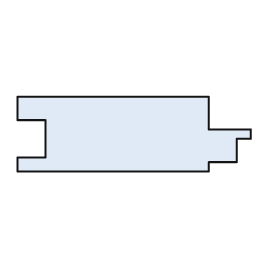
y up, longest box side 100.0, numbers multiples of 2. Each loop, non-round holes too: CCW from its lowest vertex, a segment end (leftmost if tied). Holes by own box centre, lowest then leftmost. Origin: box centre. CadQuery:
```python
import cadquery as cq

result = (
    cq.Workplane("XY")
    .moveTo(-50.0, -16.0)
    .lineTo(32.0, -16.0)
    .lineTo(32.0, -12.0)
    .lineTo(44.0, -12.0)
    .lineTo(44.0, -2.0)
    .lineTo(50.0, -2.0)
    .lineTo(50.0, 2.0)
    .lineTo(32.0, 2.0)
    .lineTo(32.0, 16.0)
    .lineTo(-50.0, 16.0)
    .lineTo(-50.0, 6.0)
    .lineTo(-38.0, 6.0)
    .lineTo(-38.0, -10.0)
    .lineTo(-50.0, -10.0)
    .close()
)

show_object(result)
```